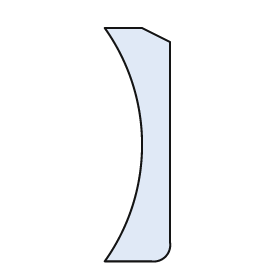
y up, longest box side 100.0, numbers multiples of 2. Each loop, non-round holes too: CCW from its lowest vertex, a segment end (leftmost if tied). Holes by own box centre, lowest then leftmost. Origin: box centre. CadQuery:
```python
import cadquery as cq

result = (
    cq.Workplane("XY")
    .moveTo(-14.0, -50.0)
    .lineTo(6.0, -50.0)
    .threePointArc((12.0, -48.0), (14.0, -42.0))
    .lineTo(14.0, 44.0)
    .lineTo(2.0, 50.0)
    .lineTo(-14.0, 50.0)
    .threePointArc((2.0, 0.0), (-14.0, -50.0))
    .close()
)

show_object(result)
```